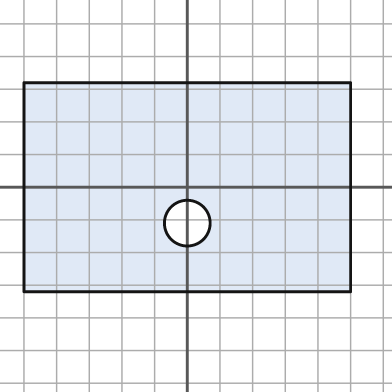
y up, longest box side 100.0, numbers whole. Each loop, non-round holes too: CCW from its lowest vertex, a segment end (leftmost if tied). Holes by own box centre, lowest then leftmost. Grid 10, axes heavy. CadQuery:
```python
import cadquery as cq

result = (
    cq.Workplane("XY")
    .moveTo(-50.0, -32.0)
    .lineTo(50.0, -32.0)
    .lineTo(50.0, 32.0)
    .lineTo(-50.0, 32.0)
    .close()
    .moveTo(0.0, -11.0)
    .circle(7.0)
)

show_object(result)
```